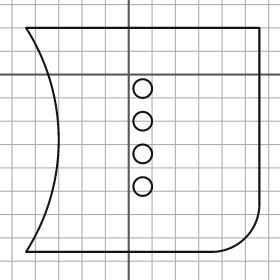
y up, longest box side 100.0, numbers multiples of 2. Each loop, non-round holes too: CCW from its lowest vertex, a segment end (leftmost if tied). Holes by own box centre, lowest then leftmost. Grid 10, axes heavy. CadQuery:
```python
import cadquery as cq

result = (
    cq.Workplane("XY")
    .moveTo(-44.0, -76.0)
    .lineTo(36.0, -76.0)
    .threePointArc((50.0, -70.0), (56.0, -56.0))
    .lineTo(56.0, 20.0)
    .lineTo(-44.0, 20.0)
    .threePointArc((-30.0, -28.0), (-44.0, -76.0))
    .close()
    .moveTo(6.0, -48.0)
    .circle(4.0)
    .moveTo(6.0, -34.0)
    .circle(4.0)
    .moveTo(6.0, -20.0)
    .circle(4.0)
    .moveTo(6.0, -6.0)
    .circle(4.0)
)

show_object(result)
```